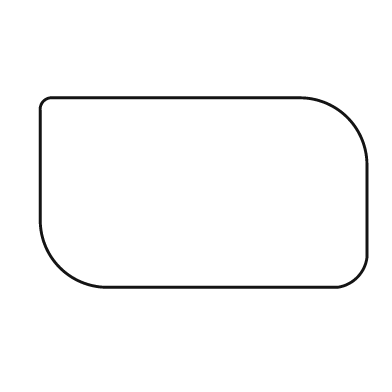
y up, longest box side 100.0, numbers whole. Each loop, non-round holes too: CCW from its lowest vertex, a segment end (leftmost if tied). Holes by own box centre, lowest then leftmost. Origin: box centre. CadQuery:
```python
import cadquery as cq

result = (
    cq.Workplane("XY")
    .moveTo(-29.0, -29.0)
    .lineTo(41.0, -29.0)
    .threePointArc((47.0, -26.0), (50.0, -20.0))
    .lineTo(50.0, 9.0)
    .threePointArc((44.0, 23.0), (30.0, 29.0))
    .lineTo(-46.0, 29.0)
    .threePointArc((-49.0, 28.0), (-50.0, 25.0))
    .lineTo(-50.0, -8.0)
    .threePointArc((-44.0, -23.0), (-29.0, -29.0))
    .close()
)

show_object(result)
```